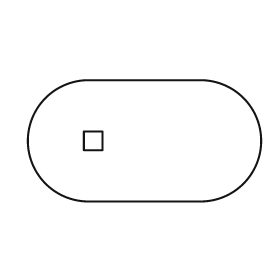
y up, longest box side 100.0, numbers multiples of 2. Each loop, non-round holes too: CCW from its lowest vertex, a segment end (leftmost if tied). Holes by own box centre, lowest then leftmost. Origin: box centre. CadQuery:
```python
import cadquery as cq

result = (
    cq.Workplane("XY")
    .moveTo(-24.0, -26.0)
    .lineTo(24.0, -26.0)
    .threePointArc((50.0, 0.0), (24.0, 26.0))
    .lineTo(-24.0, 26.0)
    .threePointArc((-50.0, 0.0), (-24.0, -26.0))
    .close()
    .moveTo(-26.0, -4.0)
    .lineTo(-18.0, -4.0)
    .lineTo(-18.0, 4.0)
    .lineTo(-26.0, 4.0)
    .close()
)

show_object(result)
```